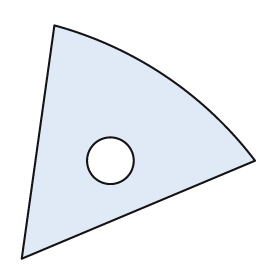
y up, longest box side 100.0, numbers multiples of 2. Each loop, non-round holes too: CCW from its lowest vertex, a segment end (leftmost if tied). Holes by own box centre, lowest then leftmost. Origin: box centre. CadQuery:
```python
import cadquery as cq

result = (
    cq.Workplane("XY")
    .moveTo(-50.0, -50.0)
    .lineTo(50.0, -8.0)
    .threePointArc((12.0, 28.0), (-36.0, 50.0))
    .close()
    .moveTo(-12.0, -8.0)
    .circle(10.0)
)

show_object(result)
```